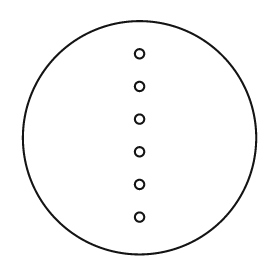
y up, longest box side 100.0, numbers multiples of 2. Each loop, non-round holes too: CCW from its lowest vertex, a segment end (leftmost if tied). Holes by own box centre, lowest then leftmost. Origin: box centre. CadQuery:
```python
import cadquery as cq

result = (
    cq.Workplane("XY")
    .moveTo(0.0, 0.0)
    .circle(50.0)
    .moveTo(0.0, -34.0)
    .circle(2.0)
    .moveTo(0.0, -20.0)
    .circle(2.0)
    .moveTo(0.0, -6.0)
    .circle(2.0)
    .moveTo(0.0, 8.0)
    .circle(2.0)
    .moveTo(0.0, 22.0)
    .circle(2.0)
    .moveTo(0.0, 36.0)
    .circle(2.0)
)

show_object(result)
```